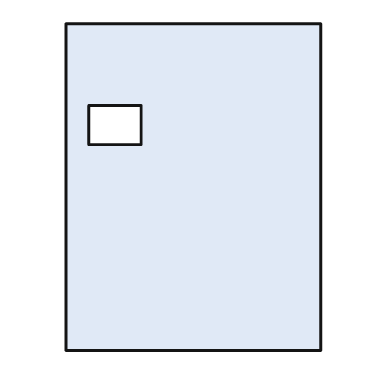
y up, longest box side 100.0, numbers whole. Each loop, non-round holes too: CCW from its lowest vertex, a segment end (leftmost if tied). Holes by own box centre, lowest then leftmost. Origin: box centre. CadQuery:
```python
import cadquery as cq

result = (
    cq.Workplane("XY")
    .moveTo(-39.0, -50.0)
    .lineTo(39.0, -50.0)
    .lineTo(39.0, 50.0)
    .lineTo(-39.0, 50.0)
    .close()
    .moveTo(-32.0, 13.0)
    .lineTo(-16.0, 13.0)
    .lineTo(-16.0, 25.0)
    .lineTo(-32.0, 25.0)
    .close()
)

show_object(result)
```